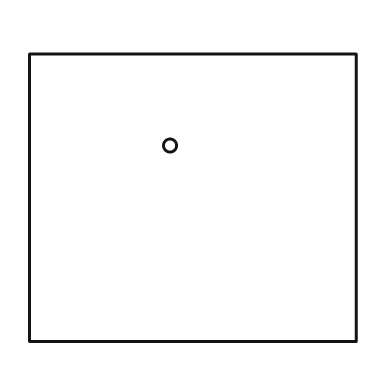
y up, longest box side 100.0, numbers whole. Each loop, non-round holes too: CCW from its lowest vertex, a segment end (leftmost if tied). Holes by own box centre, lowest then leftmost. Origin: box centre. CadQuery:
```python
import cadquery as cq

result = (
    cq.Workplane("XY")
    .moveTo(-50.0, -44.0)
    .lineTo(50.0, -44.0)
    .lineTo(50.0, 44.0)
    .lineTo(-50.0, 44.0)
    .close()
    .moveTo(-7.0, 16.0)
    .circle(2.0)
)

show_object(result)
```